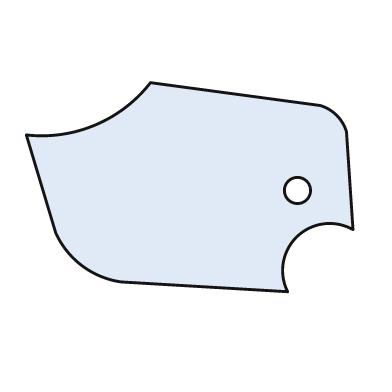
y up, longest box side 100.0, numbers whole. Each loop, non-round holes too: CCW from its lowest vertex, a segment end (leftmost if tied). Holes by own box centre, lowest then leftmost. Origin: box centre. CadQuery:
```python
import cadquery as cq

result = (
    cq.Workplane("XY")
    .moveTo(30.0, -32.0)
    .threePointArc((33.0, -15.0), (50.0, -13.0))
    .lineTo(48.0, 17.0)
    .threePointArc((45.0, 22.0), (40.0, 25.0))
    .lineTo(-12.0, 32.0)
    .threePointArc((-29.0, 19.0), (-50.0, 16.0))
    .lineTo(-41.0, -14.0)
    .threePointArc((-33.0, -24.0), (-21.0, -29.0))
    .close()
    .moveTo(33.0, -1.0)
    .circle(4.0)
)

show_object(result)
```